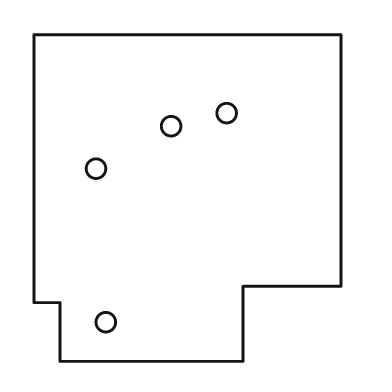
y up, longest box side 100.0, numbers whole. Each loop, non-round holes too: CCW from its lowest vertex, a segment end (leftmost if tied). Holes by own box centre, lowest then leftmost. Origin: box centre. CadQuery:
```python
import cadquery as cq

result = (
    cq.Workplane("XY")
    .moveTo(-39.0, -50.0)
    .lineTo(17.0, -50.0)
    .lineTo(17.0, -27.0)
    .lineTo(47.0, -27.0)
    .lineTo(47.0, 50.0)
    .lineTo(-47.0, 50.0)
    .lineTo(-47.0, -32.0)
    .lineTo(-39.0, -32.0)
    .close()
    .moveTo(-25.0, -38.0)
    .circle(3.0)
    .moveTo(-28.0, 9.0)
    .circle(3.0)
    .moveTo(-5.0, 22.0)
    .circle(3.0)
    .moveTo(12.0, 26.0)
    .circle(3.0)
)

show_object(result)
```